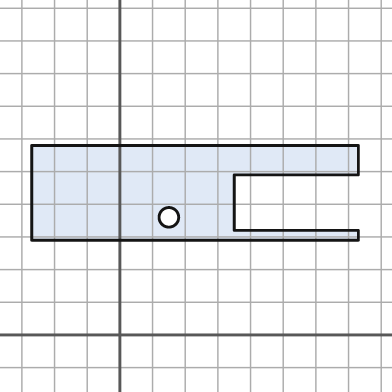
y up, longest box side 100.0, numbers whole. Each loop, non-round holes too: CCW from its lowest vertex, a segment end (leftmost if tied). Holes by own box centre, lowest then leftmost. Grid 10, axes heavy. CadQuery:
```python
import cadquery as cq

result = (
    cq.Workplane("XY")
    .moveTo(-27.0, 29.0)
    .lineTo(73.0, 29.0)
    .lineTo(73.0, 32.0)
    .lineTo(35.0, 32.0)
    .lineTo(35.0, 49.0)
    .lineTo(73.0, 49.0)
    .lineTo(73.0, 58.0)
    .lineTo(-27.0, 58.0)
    .close()
    .moveTo(15.0, 36.0)
    .circle(3.0)
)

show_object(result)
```